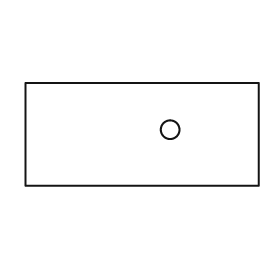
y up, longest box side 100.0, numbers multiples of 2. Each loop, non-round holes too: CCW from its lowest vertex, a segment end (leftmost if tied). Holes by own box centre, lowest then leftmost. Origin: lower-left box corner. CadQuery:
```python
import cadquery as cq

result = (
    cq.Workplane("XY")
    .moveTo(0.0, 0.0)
    .lineTo(100.0, 0.0)
    .lineTo(100.0, 44.0)
    .lineTo(0.0, 44.0)
    .close()
    .moveTo(62.0, 24.0)
    .circle(4.0)
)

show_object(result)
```